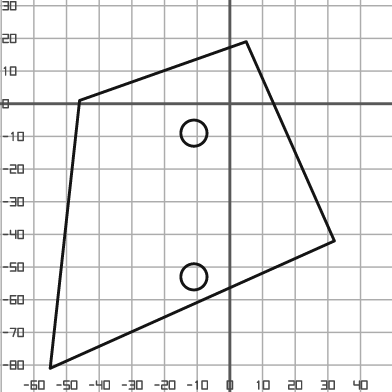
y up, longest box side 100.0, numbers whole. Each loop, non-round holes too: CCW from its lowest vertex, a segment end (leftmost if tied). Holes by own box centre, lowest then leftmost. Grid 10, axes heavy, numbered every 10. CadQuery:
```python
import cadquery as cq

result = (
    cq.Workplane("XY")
    .moveTo(-55.0, -81.0)
    .lineTo(32.0, -42.0)
    .lineTo(5.0, 19.0)
    .lineTo(-46.0, 1.0)
    .close()
    .moveTo(-11.0, -53.0)
    .circle(4.0)
    .moveTo(-11.0, -9.0)
    .circle(4.0)
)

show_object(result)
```